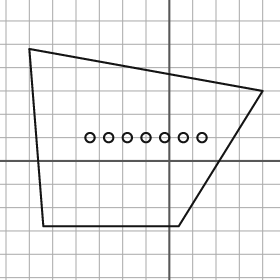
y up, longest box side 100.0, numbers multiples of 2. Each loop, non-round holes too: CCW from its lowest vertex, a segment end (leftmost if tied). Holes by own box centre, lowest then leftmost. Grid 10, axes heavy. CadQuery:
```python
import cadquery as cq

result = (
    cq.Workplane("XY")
    .moveTo(-54.0, -28.0)
    .lineTo(4.0, -28.0)
    .lineTo(40.0, 30.0)
    .lineTo(-60.0, 48.0)
    .close()
    .moveTo(-34.0, 10.0)
    .circle(2.0)
    .moveTo(-26.0, 10.0)
    .circle(2.0)
    .moveTo(-18.0, 10.0)
    .circle(2.0)
    .moveTo(-10.0, 10.0)
    .circle(2.0)
    .moveTo(-2.0, 10.0)
    .circle(2.0)
    .moveTo(6.0, 10.0)
    .circle(2.0)
    .moveTo(14.0, 10.0)
    .circle(2.0)
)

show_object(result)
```